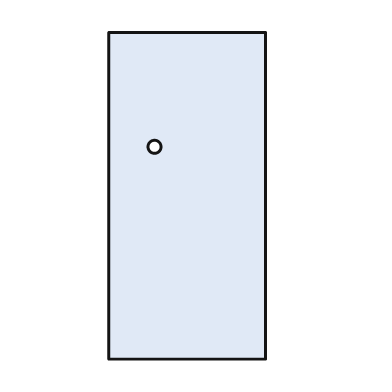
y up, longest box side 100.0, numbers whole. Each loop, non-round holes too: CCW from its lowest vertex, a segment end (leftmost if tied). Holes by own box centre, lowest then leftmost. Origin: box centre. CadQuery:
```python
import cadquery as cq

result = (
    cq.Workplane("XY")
    .moveTo(-24.0, -50.0)
    .lineTo(24.0, -50.0)
    .lineTo(24.0, 50.0)
    .lineTo(-24.0, 50.0)
    .close()
    .moveTo(-10.0, 15.0)
    .circle(2.0)
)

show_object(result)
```